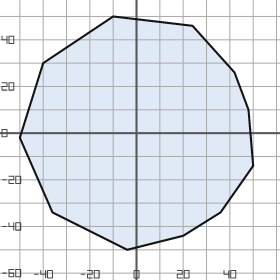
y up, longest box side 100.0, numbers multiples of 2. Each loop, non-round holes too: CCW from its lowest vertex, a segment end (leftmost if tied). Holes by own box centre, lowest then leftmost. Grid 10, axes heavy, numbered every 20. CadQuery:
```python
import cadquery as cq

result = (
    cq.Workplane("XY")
    .moveTo(-4.0, -50.0)
    .lineTo(20.0, -44.0)
    .lineTo(36.0, -34.0)
    .lineTo(50.0, -14.0)
    .lineTo(48.0, 10.0)
    .lineTo(42.0, 26.0)
    .lineTo(24.0, 46.0)
    .lineTo(-10.0, 50.0)
    .lineTo(-40.0, 30.0)
    .lineTo(-50.0, -2.0)
    .lineTo(-36.0, -34.0)
    .close()
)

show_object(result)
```